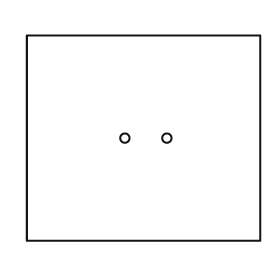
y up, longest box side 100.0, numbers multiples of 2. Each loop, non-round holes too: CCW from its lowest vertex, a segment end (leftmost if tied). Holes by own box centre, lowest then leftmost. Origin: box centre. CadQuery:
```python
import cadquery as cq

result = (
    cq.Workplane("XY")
    .moveTo(-50.0, -44.0)
    .lineTo(50.0, -44.0)
    .lineTo(50.0, 44.0)
    .lineTo(-50.0, 44.0)
    .close()
    .moveTo(-8.0, 0.0)
    .circle(2.0)
    .moveTo(10.0, 0.0)
    .circle(2.0)
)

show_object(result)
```